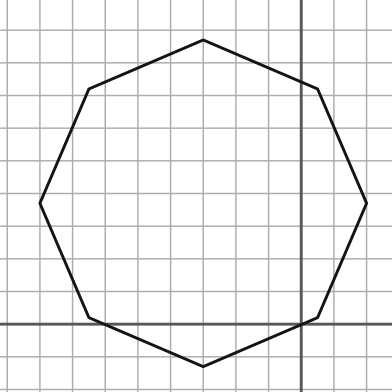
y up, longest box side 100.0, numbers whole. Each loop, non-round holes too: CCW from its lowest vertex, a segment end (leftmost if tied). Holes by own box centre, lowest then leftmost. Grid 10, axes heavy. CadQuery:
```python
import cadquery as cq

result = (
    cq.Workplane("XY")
    .moveTo(-30.0, -13.0)
    .lineTo(5.0, 2.0)
    .lineTo(20.0, 37.0)
    .lineTo(5.0, 72.0)
    .lineTo(-30.0, 87.0)
    .lineTo(-65.0, 72.0)
    .lineTo(-80.0, 37.0)
    .lineTo(-65.0, 2.0)
    .close()
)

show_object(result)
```